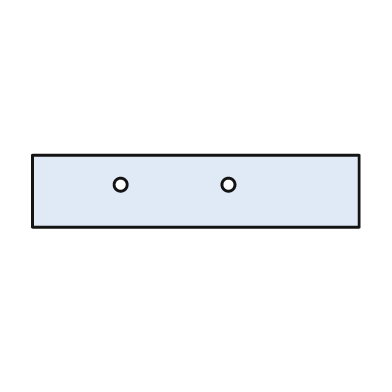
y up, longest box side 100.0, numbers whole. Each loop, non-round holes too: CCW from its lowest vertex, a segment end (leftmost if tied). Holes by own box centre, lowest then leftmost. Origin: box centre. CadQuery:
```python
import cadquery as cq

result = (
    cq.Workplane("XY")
    .moveTo(-50.0, -11.0)
    .lineTo(50.0, -11.0)
    .lineTo(50.0, 11.0)
    .lineTo(-50.0, 11.0)
    .close()
    .moveTo(-23.0, 2.0)
    .circle(2.0)
    .moveTo(10.0, 2.0)
    .circle(2.0)
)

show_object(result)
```